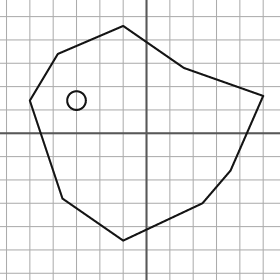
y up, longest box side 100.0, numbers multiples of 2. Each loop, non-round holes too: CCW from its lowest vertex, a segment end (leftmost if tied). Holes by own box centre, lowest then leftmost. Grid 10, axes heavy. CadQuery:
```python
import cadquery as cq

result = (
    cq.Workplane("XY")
    .moveTo(-10.0, -46.0)
    .lineTo(24.0, -30.0)
    .lineTo(36.0, -16.0)
    .lineTo(50.0, 16.0)
    .lineTo(16.0, 28.0)
    .lineTo(-10.0, 46.0)
    .lineTo(-38.0, 34.0)
    .lineTo(-50.0, 14.0)
    .lineTo(-36.0, -28.0)
    .close()
    .moveTo(-30.0, 14.0)
    .circle(4.0)
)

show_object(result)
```